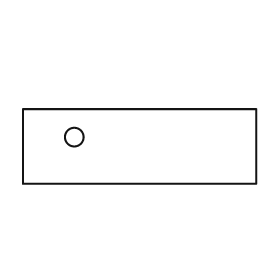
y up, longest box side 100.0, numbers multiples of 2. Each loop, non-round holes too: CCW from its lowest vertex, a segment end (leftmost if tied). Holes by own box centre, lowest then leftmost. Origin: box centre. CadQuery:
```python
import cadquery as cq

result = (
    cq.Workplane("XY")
    .moveTo(-50.0, -16.0)
    .lineTo(50.0, -16.0)
    .lineTo(50.0, 16.0)
    .lineTo(-50.0, 16.0)
    .close()
    .moveTo(-28.0, 4.0)
    .circle(4.0)
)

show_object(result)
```